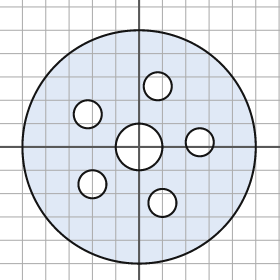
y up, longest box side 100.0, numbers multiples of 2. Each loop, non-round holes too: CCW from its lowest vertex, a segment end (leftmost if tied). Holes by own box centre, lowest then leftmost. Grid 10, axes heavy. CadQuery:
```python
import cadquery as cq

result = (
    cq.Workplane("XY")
    .moveTo(0.0, 0.0)
    .circle(50.0)
    .moveTo(10.0, -24.0)
    .circle(6.0)
    .moveTo(-20.0, -16.0)
    .circle(6.0)
    .moveTo(0.0, 0.0)
    .circle(10.0)
    .moveTo(26.0, 2.0)
    .circle(6.0)
    .moveTo(-22.0, 14.0)
    .circle(6.0)
    .moveTo(8.0, 26.0)
    .circle(6.0)
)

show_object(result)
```